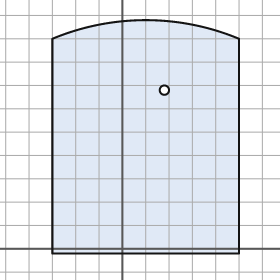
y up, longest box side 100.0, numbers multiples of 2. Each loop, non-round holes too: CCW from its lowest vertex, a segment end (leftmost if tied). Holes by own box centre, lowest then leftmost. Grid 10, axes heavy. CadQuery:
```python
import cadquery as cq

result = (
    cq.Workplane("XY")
    .moveTo(-30.0, -2.0)
    .lineTo(50.0, -2.0)
    .lineTo(50.0, 90.0)
    .threePointArc((10.0, 98.0), (-30.0, 90.0))
    .close()
    .moveTo(18.0, 68.0)
    .circle(2.0)
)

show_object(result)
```